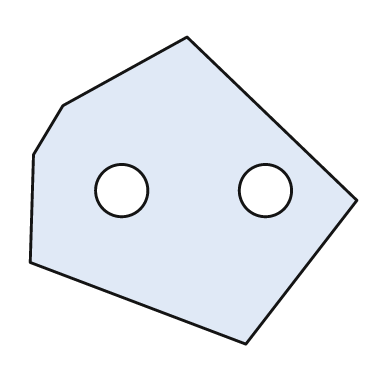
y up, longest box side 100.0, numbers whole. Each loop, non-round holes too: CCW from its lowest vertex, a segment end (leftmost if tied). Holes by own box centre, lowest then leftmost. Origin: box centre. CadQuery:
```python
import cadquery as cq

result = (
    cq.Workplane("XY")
    .moveTo(16.0, -47.0)
    .lineTo(50.0, -3.0)
    .lineTo(-2.0, 47.0)
    .lineTo(-40.0, 26.0)
    .lineTo(-49.0, 11.0)
    .lineTo(-50.0, -22.0)
    .close()
    .moveTo(-22.0, 0.0)
    .circle(8.0)
    .moveTo(22.0, 0.0)
    .circle(8.0)
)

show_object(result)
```